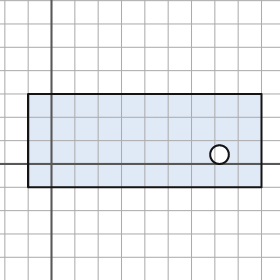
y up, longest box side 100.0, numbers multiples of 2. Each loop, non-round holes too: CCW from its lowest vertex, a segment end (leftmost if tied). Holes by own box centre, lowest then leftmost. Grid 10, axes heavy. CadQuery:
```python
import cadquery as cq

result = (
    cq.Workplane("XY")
    .moveTo(-10.0, -10.0)
    .lineTo(90.0, -10.0)
    .lineTo(90.0, 30.0)
    .lineTo(-10.0, 30.0)
    .close()
    .moveTo(72.0, 4.0)
    .circle(4.0)
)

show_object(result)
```